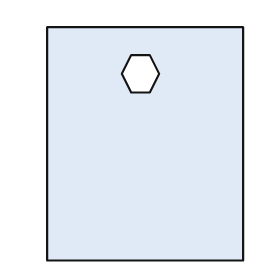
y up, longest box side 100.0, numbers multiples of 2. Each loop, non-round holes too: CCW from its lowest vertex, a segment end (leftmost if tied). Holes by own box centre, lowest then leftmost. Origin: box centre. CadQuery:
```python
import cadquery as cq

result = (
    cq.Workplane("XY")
    .moveTo(-42.0, -50.0)
    .lineTo(42.0, -50.0)
    .lineTo(42.0, 50.0)
    .lineTo(-42.0, 50.0)
    .close()
    .moveTo(-6.0, 22.0)
    .lineTo(2.0, 22.0)
    .lineTo(6.0, 30.0)
    .lineTo(2.0, 38.0)
    .lineTo(-6.0, 38.0)
    .lineTo(-10.0, 30.0)
    .close()
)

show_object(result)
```